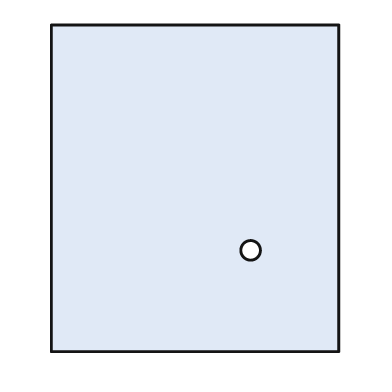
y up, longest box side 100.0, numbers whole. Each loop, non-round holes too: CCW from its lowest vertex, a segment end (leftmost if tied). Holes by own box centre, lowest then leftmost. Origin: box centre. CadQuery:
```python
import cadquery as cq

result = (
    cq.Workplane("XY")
    .moveTo(-44.0, -50.0)
    .lineTo(44.0, -50.0)
    .lineTo(44.0, 50.0)
    .lineTo(-44.0, 50.0)
    .close()
    .moveTo(17.0, -19.0)
    .circle(3.0)
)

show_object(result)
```